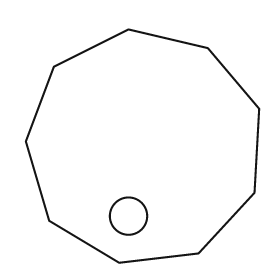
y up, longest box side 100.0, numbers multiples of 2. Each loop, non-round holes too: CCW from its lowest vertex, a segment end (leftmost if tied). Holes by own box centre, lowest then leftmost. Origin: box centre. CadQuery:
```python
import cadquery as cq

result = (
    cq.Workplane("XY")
    .moveTo(-10.0, -50.0)
    .lineTo(24.0, -46.0)
    .lineTo(48.0, -20.0)
    .lineTo(50.0, 16.0)
    .lineTo(28.0, 42.0)
    .lineTo(-6.0, 50.0)
    .lineTo(-38.0, 34.0)
    .lineTo(-50.0, 2.0)
    .lineTo(-40.0, -32.0)
    .close()
    .moveTo(-6.0, -30.0)
    .circle(8.0)
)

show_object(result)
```